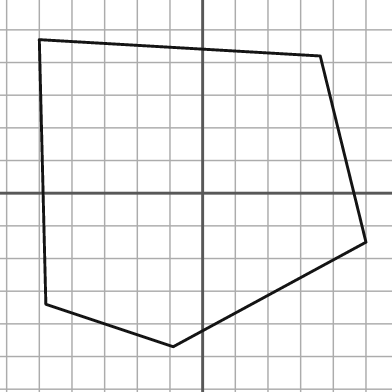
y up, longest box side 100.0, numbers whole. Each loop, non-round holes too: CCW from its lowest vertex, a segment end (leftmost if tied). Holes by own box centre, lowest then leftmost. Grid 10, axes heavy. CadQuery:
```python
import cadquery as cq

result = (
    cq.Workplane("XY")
    .moveTo(-9.0, -47.0)
    .lineTo(50.0, -15.0)
    .lineTo(36.0, 42.0)
    .lineTo(-50.0, 47.0)
    .lineTo(-48.0, -34.0)
    .close()
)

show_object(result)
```